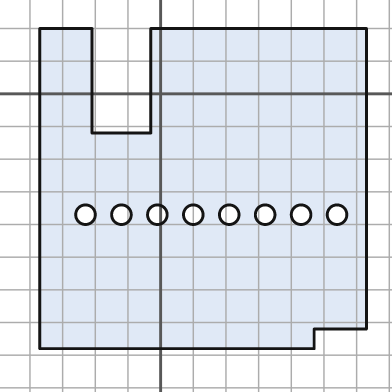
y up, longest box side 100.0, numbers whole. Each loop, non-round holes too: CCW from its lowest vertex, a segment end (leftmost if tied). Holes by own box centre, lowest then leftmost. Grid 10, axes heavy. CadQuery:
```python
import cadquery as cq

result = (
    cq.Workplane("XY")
    .moveTo(-37.0, -78.0)
    .lineTo(47.0, -78.0)
    .lineTo(47.0, -72.0)
    .lineTo(63.0, -72.0)
    .lineTo(63.0, 20.0)
    .lineTo(-3.0, 20.0)
    .lineTo(-3.0, -12.0)
    .lineTo(-21.0, -12.0)
    .lineTo(-21.0, 20.0)
    .lineTo(-37.0, 20.0)
    .close()
    .moveTo(-23.0, -37.0)
    .circle(3.0)
    .moveTo(-12.0, -37.0)
    .circle(3.0)
    .moveTo(-1.0, -37.0)
    .circle(3.0)
    .moveTo(10.0, -37.0)
    .circle(3.0)
    .moveTo(21.0, -37.0)
    .circle(3.0)
    .moveTo(32.0, -37.0)
    .circle(3.0)
    .moveTo(43.0, -37.0)
    .circle(3.0)
    .moveTo(54.0, -37.0)
    .circle(3.0)
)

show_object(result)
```